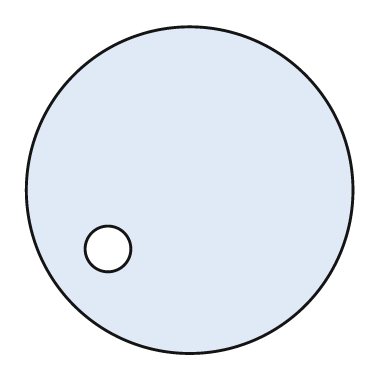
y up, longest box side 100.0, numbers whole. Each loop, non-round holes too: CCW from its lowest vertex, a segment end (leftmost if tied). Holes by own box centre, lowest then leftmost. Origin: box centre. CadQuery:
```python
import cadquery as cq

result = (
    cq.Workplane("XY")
    .moveTo(0.0, 0.0)
    .circle(50.0)
    .moveTo(-25.0, -18.0)
    .circle(7.0)
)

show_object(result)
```